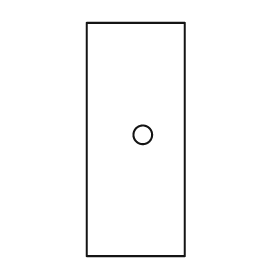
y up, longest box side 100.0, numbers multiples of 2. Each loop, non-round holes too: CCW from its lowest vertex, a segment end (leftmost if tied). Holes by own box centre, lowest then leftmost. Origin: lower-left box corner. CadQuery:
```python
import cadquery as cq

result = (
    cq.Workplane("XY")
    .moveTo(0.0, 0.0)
    .lineTo(42.0, 0.0)
    .lineTo(42.0, 100.0)
    .lineTo(0.0, 100.0)
    .close()
    .moveTo(24.0, 52.0)
    .circle(4.0)
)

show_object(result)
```